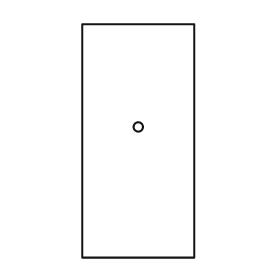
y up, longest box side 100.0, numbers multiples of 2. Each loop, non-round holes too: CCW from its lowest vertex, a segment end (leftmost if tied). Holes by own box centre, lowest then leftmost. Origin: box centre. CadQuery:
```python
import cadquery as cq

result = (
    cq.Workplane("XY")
    .moveTo(-24.0, -50.0)
    .lineTo(24.0, -50.0)
    .lineTo(24.0, 50.0)
    .lineTo(-24.0, 50.0)
    .close()
    .moveTo(0.0, 6.0)
    .circle(2.0)
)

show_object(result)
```